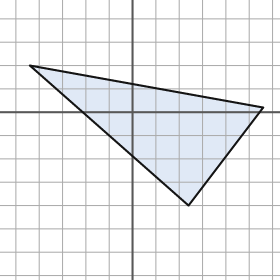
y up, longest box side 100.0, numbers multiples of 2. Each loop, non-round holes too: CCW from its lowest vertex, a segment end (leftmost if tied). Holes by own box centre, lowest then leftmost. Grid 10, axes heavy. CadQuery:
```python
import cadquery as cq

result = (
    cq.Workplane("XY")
    .moveTo(24.0, -40.0)
    .lineTo(56.0, 2.0)
    .lineTo(-44.0, 20.0)
    .close()
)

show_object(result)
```